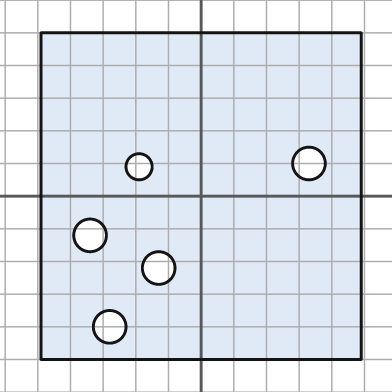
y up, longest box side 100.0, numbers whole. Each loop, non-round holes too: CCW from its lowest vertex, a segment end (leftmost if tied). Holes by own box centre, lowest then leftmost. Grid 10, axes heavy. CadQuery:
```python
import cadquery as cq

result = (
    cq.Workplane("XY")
    .moveTo(-49.0, -50.0)
    .lineTo(49.0, -50.0)
    .lineTo(49.0, 50.0)
    .lineTo(-49.0, 50.0)
    .close()
    .moveTo(-28.0, -40.0)
    .circle(5.0)
    .moveTo(-13.0, -22.0)
    .circle(5.0)
    .moveTo(-34.0, -12.0)
    .circle(5.0)
    .moveTo(-19.0, 9.0)
    .circle(4.0)
    .moveTo(33.0, 10.0)
    .circle(5.0)
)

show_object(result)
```